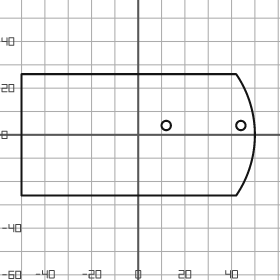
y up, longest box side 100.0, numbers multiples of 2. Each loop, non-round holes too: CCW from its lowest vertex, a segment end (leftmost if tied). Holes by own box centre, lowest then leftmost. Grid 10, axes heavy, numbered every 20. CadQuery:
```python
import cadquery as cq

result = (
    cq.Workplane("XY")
    .moveTo(-50.0, -26.0)
    .lineTo(42.0, -26.0)
    .threePointArc((50.0, 0.0), (42.0, 26.0))
    .lineTo(-50.0, 26.0)
    .close()
    .moveTo(12.0, 4.0)
    .circle(2.0)
    .moveTo(44.0, 4.0)
    .circle(2.0)
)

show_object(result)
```